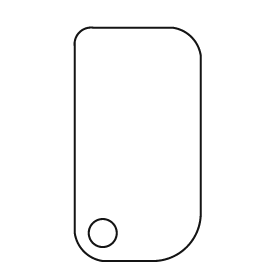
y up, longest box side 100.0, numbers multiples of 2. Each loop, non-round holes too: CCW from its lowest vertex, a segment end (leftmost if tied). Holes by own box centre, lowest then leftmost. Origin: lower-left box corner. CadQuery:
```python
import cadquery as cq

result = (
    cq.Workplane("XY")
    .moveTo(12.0, 0.0)
    .lineTo(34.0, 0.0)
    .threePointArc((48.0, 6.0), (54.0, 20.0))
    .lineTo(54.0, 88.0)
    .threePointArc((50.0, 96.0), (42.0, 100.0))
    .lineTo(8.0, 100.0)
    .threePointArc((2.0, 98.0), (0.0, 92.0))
    .lineTo(0.0, 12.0)
    .threePointArc((4.0, 4.0), (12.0, 0.0))
    .close()
    .moveTo(12.0, 12.0)
    .circle(6.0)
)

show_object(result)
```